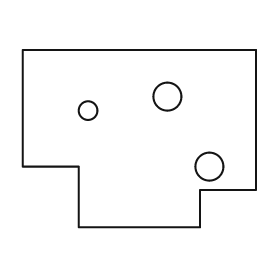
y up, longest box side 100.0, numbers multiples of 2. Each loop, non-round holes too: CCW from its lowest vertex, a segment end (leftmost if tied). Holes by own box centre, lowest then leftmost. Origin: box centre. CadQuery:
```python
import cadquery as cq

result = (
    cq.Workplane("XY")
    .moveTo(-26.0, -38.0)
    .lineTo(26.0, -38.0)
    .lineTo(26.0, -22.0)
    .lineTo(50.0, -22.0)
    .lineTo(50.0, 38.0)
    .lineTo(-50.0, 38.0)
    .lineTo(-50.0, -12.0)
    .lineTo(-26.0, -12.0)
    .close()
    .moveTo(30.0, -12.0)
    .circle(6.0)
    .moveTo(-22.0, 12.0)
    .circle(4.0)
    .moveTo(12.0, 18.0)
    .circle(6.0)
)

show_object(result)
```